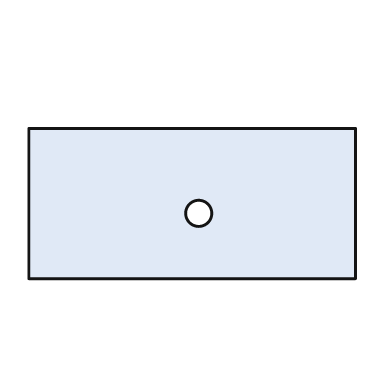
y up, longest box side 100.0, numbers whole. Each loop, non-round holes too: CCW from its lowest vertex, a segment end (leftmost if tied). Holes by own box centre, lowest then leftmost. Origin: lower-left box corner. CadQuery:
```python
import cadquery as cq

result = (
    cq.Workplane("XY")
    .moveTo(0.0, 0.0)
    .lineTo(100.0, 0.0)
    .lineTo(100.0, 46.0)
    .lineTo(0.0, 46.0)
    .close()
    .moveTo(52.0, 20.0)
    .circle(4.0)
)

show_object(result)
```